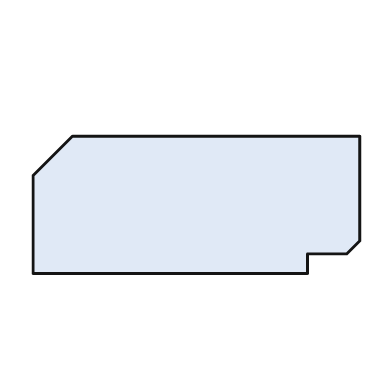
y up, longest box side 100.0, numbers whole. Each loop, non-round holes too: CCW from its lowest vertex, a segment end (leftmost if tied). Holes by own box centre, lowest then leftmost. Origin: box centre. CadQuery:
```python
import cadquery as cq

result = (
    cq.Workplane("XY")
    .moveTo(-50.0, -21.0)
    .lineTo(34.0, -21.0)
    .lineTo(34.0, -15.0)
    .lineTo(46.0, -15.0)
    .lineTo(50.0, -11.0)
    .lineTo(50.0, 21.0)
    .lineTo(-38.0, 21.0)
    .lineTo(-50.0, 9.0)
    .close()
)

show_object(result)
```